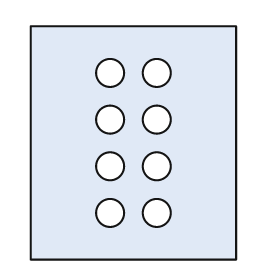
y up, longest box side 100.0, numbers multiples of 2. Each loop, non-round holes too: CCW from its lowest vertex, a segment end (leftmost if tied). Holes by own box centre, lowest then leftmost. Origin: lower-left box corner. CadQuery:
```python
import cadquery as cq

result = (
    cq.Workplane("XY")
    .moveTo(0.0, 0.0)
    .lineTo(88.0, 0.0)
    .lineTo(88.0, 100.0)
    .lineTo(0.0, 100.0)
    .close()
    .moveTo(34.0, 20.0)
    .circle(6.0)
    .moveTo(54.0, 20.0)
    .circle(6.0)
    .moveTo(34.0, 40.0)
    .circle(6.0)
    .moveTo(54.0, 40.0)
    .circle(6.0)
    .moveTo(34.0, 60.0)
    .circle(6.0)
    .moveTo(54.0, 60.0)
    .circle(6.0)
    .moveTo(34.0, 80.0)
    .circle(6.0)
    .moveTo(54.0, 80.0)
    .circle(6.0)
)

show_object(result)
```